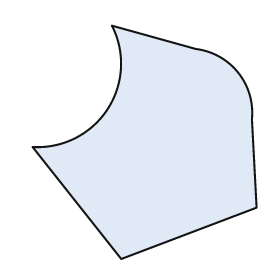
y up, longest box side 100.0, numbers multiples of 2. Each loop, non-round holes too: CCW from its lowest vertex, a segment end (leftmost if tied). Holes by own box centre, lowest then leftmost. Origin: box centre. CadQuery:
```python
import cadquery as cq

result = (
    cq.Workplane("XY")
    .moveTo(-10.0, -50.0)
    .lineTo(48.0, -28.0)
    .lineTo(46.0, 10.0)
    .threePointArc((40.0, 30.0), (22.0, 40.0))
    .lineTo(-14.0, 50.0)
    .threePointArc((-16.0, 14.0), (-48.0, -2.0))
    .close()
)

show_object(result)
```